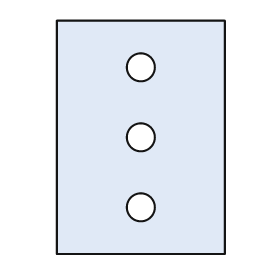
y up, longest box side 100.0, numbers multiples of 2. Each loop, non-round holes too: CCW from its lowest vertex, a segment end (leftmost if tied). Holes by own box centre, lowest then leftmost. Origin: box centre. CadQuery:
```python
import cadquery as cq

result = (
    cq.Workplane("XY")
    .moveTo(-36.0, -50.0)
    .lineTo(36.0, -50.0)
    .lineTo(36.0, 50.0)
    .lineTo(-36.0, 50.0)
    .close()
    .moveTo(0.0, -30.0)
    .circle(6.0)
    .moveTo(0.0, 0.0)
    .circle(6.0)
    .moveTo(0.0, 30.0)
    .circle(6.0)
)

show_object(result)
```